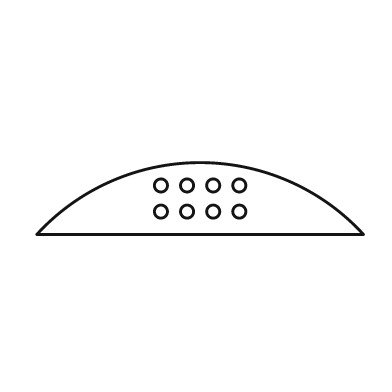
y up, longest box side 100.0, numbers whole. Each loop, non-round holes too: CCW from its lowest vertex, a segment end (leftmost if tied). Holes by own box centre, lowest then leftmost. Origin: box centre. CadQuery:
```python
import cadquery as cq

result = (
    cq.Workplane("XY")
    .moveTo(-50.0, -11.0)
    .lineTo(50.0, -11.0)
    .threePointArc((0.0, 11.0), (-50.0, -11.0))
    .close()
    .moveTo(-12.0, -4.0)
    .circle(2.0)
    .moveTo(-4.0, -4.0)
    .circle(2.0)
    .moveTo(4.0, -4.0)
    .circle(2.0)
    .moveTo(12.0, -4.0)
    .circle(2.0)
    .moveTo(-12.0, 4.0)
    .circle(2.0)
    .moveTo(-4.0, 4.0)
    .circle(2.0)
    .moveTo(4.0, 4.0)
    .circle(2.0)
    .moveTo(12.0, 4.0)
    .circle(2.0)
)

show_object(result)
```